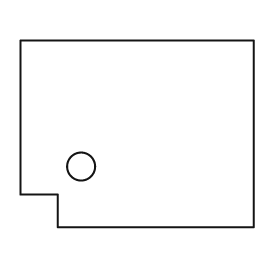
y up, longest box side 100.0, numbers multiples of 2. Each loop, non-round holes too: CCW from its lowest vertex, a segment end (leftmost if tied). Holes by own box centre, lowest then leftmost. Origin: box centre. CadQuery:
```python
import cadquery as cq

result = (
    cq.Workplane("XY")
    .moveTo(-34.0, -40.0)
    .lineTo(50.0, -40.0)
    .lineTo(50.0, 40.0)
    .lineTo(-50.0, 40.0)
    .lineTo(-50.0, -26.0)
    .lineTo(-34.0, -26.0)
    .close()
    .moveTo(-24.0, -14.0)
    .circle(6.0)
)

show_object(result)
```